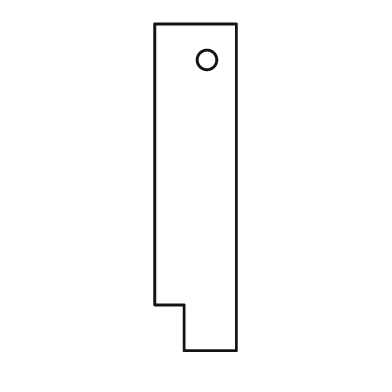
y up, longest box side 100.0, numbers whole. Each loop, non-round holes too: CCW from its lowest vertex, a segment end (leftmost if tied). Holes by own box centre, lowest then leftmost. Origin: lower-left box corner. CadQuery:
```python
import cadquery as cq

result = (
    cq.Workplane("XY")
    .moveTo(9.0, 0.0)
    .lineTo(25.0, 0.0)
    .lineTo(25.0, 100.0)
    .lineTo(0.0, 100.0)
    .lineTo(0.0, 14.0)
    .lineTo(9.0, 14.0)
    .close()
    .moveTo(16.0, 89.0)
    .circle(3.0)
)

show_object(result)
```